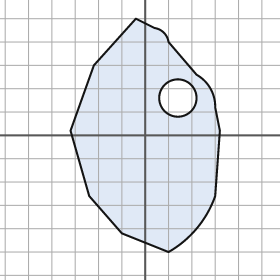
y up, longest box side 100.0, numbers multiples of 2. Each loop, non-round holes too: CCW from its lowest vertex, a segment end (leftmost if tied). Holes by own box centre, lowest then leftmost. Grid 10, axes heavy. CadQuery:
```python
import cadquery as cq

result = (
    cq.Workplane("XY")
    .moveTo(10.0, -50.0)
    .threePointArc((22.0, -40.0), (30.0, -26.0))
    .lineTo(32.0, 2.0)
    .lineTo(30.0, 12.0)
    .threePointArc((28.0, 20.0), (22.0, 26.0))
    .lineTo(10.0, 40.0)
    .threePointArc((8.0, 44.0), (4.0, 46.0))
    .lineTo(-4.0, 50.0)
    .lineTo(-22.0, 30.0)
    .lineTo(-32.0, 2.0)
    .lineTo(-24.0, -26.0)
    .lineTo(-10.0, -42.0)
    .close()
    .moveTo(14.0, 16.0)
    .circle(8.0)
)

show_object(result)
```